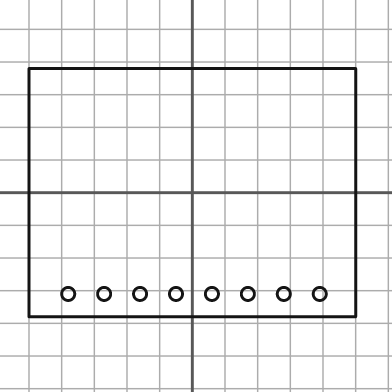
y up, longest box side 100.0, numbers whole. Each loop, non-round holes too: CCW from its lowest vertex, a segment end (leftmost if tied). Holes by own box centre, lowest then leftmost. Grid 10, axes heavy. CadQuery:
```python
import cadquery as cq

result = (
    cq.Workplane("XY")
    .moveTo(-50.0, -38.0)
    .lineTo(50.0, -38.0)
    .lineTo(50.0, 38.0)
    .lineTo(-50.0, 38.0)
    .close()
    .moveTo(-38.0, -31.0)
    .circle(2.0)
    .moveTo(-27.0, -31.0)
    .circle(2.0)
    .moveTo(-16.0, -31.0)
    .circle(2.0)
    .moveTo(-5.0, -31.0)
    .circle(2.0)
    .moveTo(6.0, -31.0)
    .circle(2.0)
    .moveTo(17.0, -31.0)
    .circle(2.0)
    .moveTo(28.0, -31.0)
    .circle(2.0)
    .moveTo(39.0, -31.0)
    .circle(2.0)
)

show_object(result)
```